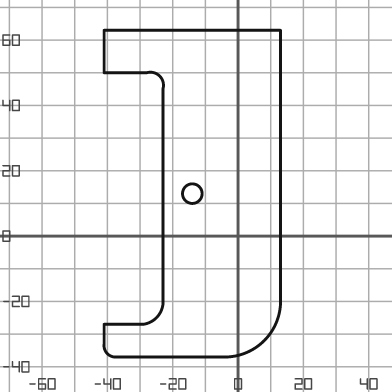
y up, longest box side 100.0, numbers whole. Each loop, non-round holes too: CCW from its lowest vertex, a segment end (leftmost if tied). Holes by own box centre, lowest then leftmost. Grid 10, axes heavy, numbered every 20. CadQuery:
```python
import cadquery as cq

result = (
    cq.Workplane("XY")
    .moveTo(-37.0, -37.0)
    .lineTo(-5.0, -37.0)
    .threePointArc((8.0, -32.0), (13.0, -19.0))
    .lineTo(13.0, 63.0)
    .lineTo(-41.0, 63.0)
    .lineTo(-41.0, 50.0)
    .lineTo(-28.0, 50.0)
    .threePointArc((-24.0, 49.0), (-23.0, 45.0))
    .lineTo(-23.0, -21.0)
    .threePointArc((-25.0, -25.0), (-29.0, -27.0))
    .lineTo(-41.0, -27.0)
    .lineTo(-41.0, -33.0)
    .threePointArc((-40.0, -36.0), (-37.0, -37.0))
    .close()
    .moveTo(-14.0, 13.0)
    .circle(3.0)
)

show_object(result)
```